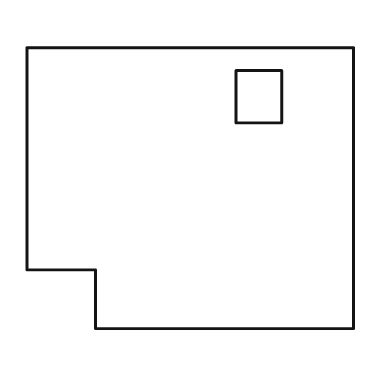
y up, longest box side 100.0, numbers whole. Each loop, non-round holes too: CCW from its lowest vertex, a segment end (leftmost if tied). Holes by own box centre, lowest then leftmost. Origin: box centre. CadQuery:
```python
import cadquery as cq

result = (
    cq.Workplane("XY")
    .moveTo(-29.0, -43.0)
    .lineTo(50.0, -43.0)
    .lineTo(50.0, 43.0)
    .lineTo(-50.0, 43.0)
    .lineTo(-50.0, -25.0)
    .lineTo(-29.0, -25.0)
    .close()
    .moveTo(14.0, 20.0)
    .lineTo(28.0, 20.0)
    .lineTo(28.0, 36.0)
    .lineTo(14.0, 36.0)
    .close()
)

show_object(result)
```